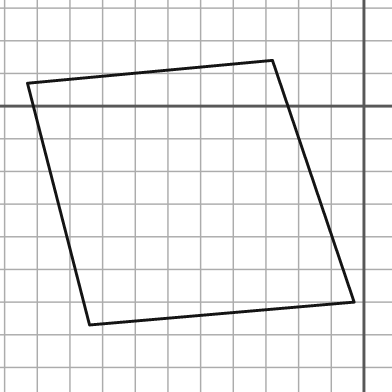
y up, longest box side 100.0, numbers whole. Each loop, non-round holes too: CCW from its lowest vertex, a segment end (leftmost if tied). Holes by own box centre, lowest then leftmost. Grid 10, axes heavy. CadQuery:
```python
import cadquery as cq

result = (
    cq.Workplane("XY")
    .moveTo(-84.0, -67.0)
    .lineTo(-3.0, -60.0)
    .lineTo(-28.0, 14.0)
    .lineTo(-103.0, 7.0)
    .close()
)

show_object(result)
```